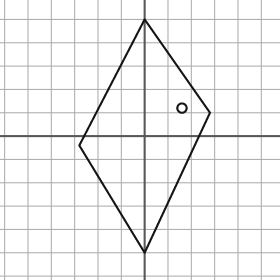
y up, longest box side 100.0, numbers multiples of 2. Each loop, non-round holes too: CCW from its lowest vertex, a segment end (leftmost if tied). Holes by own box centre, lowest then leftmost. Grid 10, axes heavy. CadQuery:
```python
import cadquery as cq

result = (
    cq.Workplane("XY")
    .moveTo(0.0, -50.0)
    .lineTo(28.0, 10.0)
    .lineTo(0.0, 50.0)
    .lineTo(-28.0, -4.0)
    .close()
    .moveTo(16.0, 12.0)
    .circle(2.0)
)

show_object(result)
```